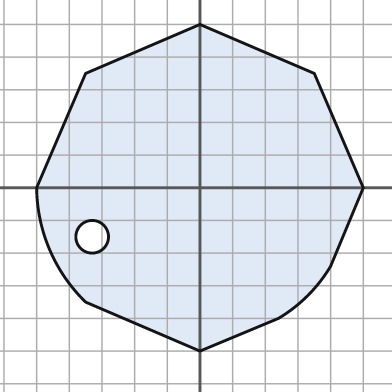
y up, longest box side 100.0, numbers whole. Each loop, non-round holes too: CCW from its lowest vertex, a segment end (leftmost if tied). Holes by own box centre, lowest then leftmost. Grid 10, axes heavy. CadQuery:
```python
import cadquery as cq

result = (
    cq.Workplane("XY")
    .moveTo(0.0, -50.0)
    .lineTo(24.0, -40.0)
    .threePointArc((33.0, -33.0), (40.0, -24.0))
    .lineTo(50.0, 0.0)
    .lineTo(35.0, 35.0)
    .lineTo(0.0, 50.0)
    .lineTo(-35.0, 35.0)
    .lineTo(-50.0, 0.0)
    .threePointArc((-46.0, -19.0), (-35.0, -35.0))
    .close()
    .moveTo(-33.0, -15.0)
    .circle(5.0)
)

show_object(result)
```